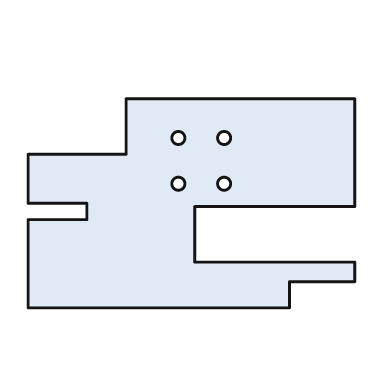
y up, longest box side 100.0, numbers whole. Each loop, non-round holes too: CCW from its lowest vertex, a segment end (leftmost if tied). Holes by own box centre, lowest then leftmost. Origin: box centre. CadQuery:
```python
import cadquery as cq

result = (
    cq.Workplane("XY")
    .moveTo(-50.0, -32.0)
    .lineTo(30.0, -32.0)
    .lineTo(30.0, -24.0)
    .lineTo(50.0, -24.0)
    .lineTo(50.0, -18.0)
    .lineTo(1.0, -18.0)
    .lineTo(1.0, -1.0)
    .lineTo(50.0, -1.0)
    .lineTo(50.0, 32.0)
    .lineTo(-20.0, 32.0)
    .lineTo(-20.0, 15.0)
    .lineTo(-50.0, 15.0)
    .lineTo(-50.0, 0.0)
    .lineTo(-32.0, 0.0)
    .lineTo(-32.0, -5.0)
    .lineTo(-50.0, -5.0)
    .close()
    .moveTo(-4.0, 6.0)
    .circle(2.0)
    .moveTo(10.0, 6.0)
    .circle(2.0)
    .moveTo(-4.0, 20.0)
    .circle(2.0)
    .moveTo(10.0, 20.0)
    .circle(2.0)
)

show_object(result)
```